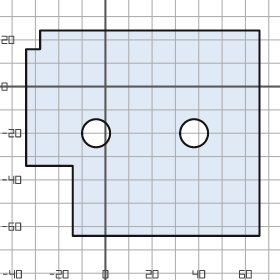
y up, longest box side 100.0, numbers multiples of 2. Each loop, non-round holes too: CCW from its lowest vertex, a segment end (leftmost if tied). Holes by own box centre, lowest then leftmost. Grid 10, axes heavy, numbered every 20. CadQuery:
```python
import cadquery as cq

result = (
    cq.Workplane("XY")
    .moveTo(-14.0, -64.0)
    .lineTo(66.0, -64.0)
    .lineTo(66.0, 24.0)
    .lineTo(-28.0, 24.0)
    .lineTo(-28.0, 16.0)
    .lineTo(-34.0, 16.0)
    .lineTo(-34.0, -34.0)
    .lineTo(-14.0, -34.0)
    .close()
    .moveTo(-4.0, -20.0)
    .circle(6.0)
    .moveTo(38.0, -20.0)
    .circle(6.0)
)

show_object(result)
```